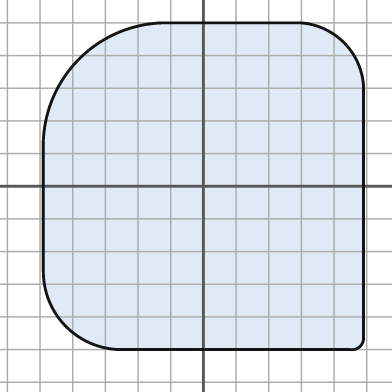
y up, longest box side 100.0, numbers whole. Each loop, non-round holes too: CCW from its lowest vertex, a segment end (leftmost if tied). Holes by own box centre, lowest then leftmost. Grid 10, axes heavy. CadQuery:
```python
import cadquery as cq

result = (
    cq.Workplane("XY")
    .moveTo(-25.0, -50.0)
    .lineTo(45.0, -50.0)
    .threePointArc((48.0, -49.0), (49.0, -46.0))
    .lineTo(49.0, 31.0)
    .threePointArc((43.0, 44.0), (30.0, 50.0))
    .lineTo(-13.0, 50.0)
    .threePointArc((-38.0, 39.0), (-49.0, 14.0))
    .lineTo(-49.0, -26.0)
    .threePointArc((-42.0, -43.0), (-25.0, -50.0))
    .close()
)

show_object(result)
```